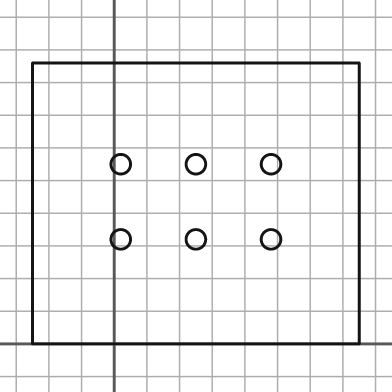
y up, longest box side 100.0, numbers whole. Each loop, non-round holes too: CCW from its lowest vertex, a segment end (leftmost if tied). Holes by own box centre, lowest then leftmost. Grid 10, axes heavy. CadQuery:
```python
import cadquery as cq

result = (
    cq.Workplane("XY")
    .moveTo(-25.0, 0.0)
    .lineTo(75.0, 0.0)
    .lineTo(75.0, 86.0)
    .lineTo(-25.0, 86.0)
    .close()
    .moveTo(2.0, 32.0)
    .circle(3.0)
    .moveTo(25.0, 32.0)
    .circle(3.0)
    .moveTo(48.0, 32.0)
    .circle(3.0)
    .moveTo(2.0, 55.0)
    .circle(3.0)
    .moveTo(25.0, 55.0)
    .circle(3.0)
    .moveTo(48.0, 55.0)
    .circle(3.0)
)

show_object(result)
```